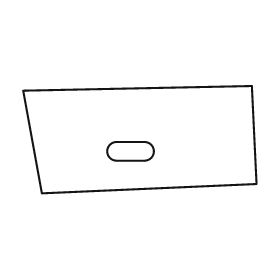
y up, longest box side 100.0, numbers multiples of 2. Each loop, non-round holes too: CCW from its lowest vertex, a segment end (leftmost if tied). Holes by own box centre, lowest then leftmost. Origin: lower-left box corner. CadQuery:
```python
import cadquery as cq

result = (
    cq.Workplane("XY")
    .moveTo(8.0, 0.0)
    .lineTo(100.0, 4.0)
    .lineTo(98.0, 46.0)
    .lineTo(0.0, 44.0)
    .close()
    .moveTo(40.0, 14.0)
    .lineTo(52.0, 14.0)
    .threePointArc((56.0, 18.0), (52.0, 22.0))
    .lineTo(40.0, 22.0)
    .threePointArc((36.0, 18.0), (40.0, 14.0))
    .close()
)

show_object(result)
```